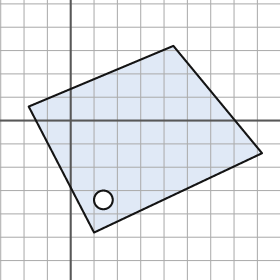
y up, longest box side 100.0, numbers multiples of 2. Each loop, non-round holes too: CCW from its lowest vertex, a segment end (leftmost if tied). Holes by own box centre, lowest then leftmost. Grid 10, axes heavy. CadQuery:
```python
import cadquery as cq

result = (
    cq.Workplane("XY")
    .moveTo(10.0, -48.0)
    .lineTo(82.0, -14.0)
    .lineTo(44.0, 32.0)
    .lineTo(-18.0, 6.0)
    .close()
    .moveTo(14.0, -34.0)
    .circle(4.0)
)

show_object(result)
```